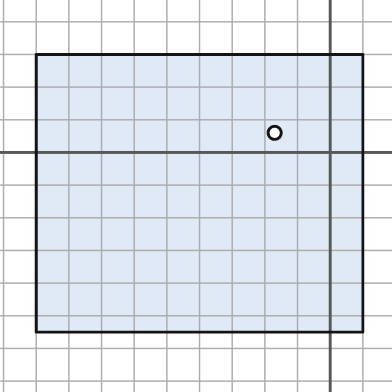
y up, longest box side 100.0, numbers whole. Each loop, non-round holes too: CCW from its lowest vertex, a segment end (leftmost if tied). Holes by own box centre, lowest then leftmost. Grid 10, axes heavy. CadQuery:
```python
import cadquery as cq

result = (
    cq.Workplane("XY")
    .moveTo(-90.0, -55.0)
    .lineTo(10.0, -55.0)
    .lineTo(10.0, 30.0)
    .lineTo(-90.0, 30.0)
    .close()
    .moveTo(-17.0, 6.0)
    .circle(2.0)
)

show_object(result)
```